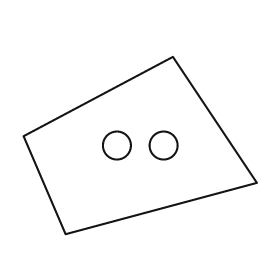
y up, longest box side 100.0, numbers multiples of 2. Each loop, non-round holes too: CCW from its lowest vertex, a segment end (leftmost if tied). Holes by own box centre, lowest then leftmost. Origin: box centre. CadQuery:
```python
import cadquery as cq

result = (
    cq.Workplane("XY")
    .moveTo(-32.0, -38.0)
    .lineTo(50.0, -16.0)
    .lineTo(14.0, 38.0)
    .lineTo(-50.0, 4.0)
    .close()
    .moveTo(-10.0, 0.0)
    .circle(6.0)
    .moveTo(10.0, 0.0)
    .circle(6.0)
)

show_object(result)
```